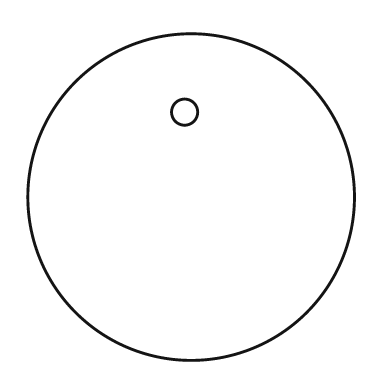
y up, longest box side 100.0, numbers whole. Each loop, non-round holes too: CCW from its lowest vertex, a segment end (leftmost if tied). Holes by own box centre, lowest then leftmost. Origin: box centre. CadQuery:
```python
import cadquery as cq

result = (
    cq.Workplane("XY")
    .moveTo(0.0, 0.0)
    .circle(50.0)
    .moveTo(-2.0, 26.0)
    .circle(4.0)
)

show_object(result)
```